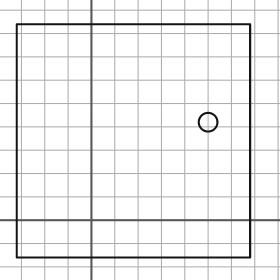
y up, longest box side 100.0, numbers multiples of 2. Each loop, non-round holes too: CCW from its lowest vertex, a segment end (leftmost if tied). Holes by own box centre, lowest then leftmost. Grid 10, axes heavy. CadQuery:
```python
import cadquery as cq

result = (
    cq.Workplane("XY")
    .moveTo(-32.0, -16.0)
    .lineTo(68.0, -16.0)
    .lineTo(68.0, 84.0)
    .lineTo(-32.0, 84.0)
    .close()
    .moveTo(50.0, 42.0)
    .circle(4.0)
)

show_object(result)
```